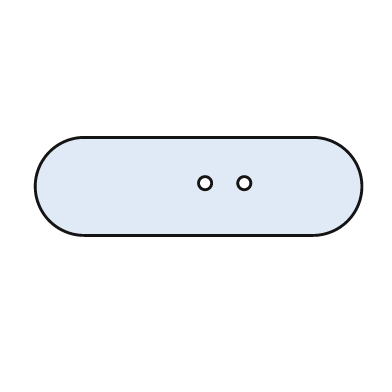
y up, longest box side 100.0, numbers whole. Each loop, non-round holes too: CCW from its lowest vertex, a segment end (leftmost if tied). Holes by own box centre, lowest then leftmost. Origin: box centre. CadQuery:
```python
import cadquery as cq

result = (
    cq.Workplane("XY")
    .moveTo(-35.0, -15.0)
    .lineTo(35.0, -15.0)
    .threePointArc((50.0, 0.0), (35.0, 15.0))
    .lineTo(-35.0, 15.0)
    .threePointArc((-50.0, 0.0), (-35.0, -15.0))
    .close()
    .moveTo(2.0, 1.0)
    .circle(2.0)
    .moveTo(14.0, 1.0)
    .circle(2.0)
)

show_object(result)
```